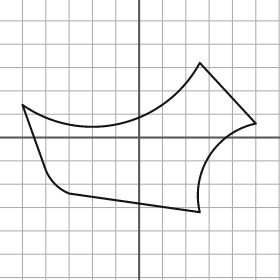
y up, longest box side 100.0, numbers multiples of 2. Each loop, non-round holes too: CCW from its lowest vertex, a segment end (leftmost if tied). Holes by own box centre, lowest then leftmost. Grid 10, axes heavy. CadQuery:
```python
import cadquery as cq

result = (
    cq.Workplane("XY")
    .moveTo(26.0, -32.0)
    .threePointArc((30.0, -8.0), (50.0, 6.0))
    .lineTo(26.0, 32.0)
    .threePointArc((-8.0, 6.0), (-50.0, 14.0))
    .lineTo(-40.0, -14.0)
    .threePointArc((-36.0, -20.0), (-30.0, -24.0))
    .close()
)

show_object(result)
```